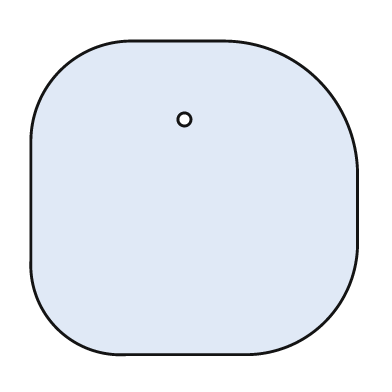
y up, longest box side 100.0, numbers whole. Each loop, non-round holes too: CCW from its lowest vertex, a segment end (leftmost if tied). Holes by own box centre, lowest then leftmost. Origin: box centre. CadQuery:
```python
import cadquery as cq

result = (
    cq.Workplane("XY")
    .moveTo(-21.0, -48.0)
    .lineTo(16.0, -48.0)
    .threePointArc((40.0, -38.0), (50.0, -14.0))
    .lineTo(50.0, 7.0)
    .threePointArc((38.0, 36.0), (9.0, 48.0))
    .lineTo(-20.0, 48.0)
    .threePointArc((-41.0, 39.0), (-50.0, 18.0))
    .lineTo(-50.0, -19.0)
    .threePointArc((-42.0, -40.0), (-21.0, -48.0))
    .close()
    .moveTo(-3.0, 24.0)
    .circle(2.0)
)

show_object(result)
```